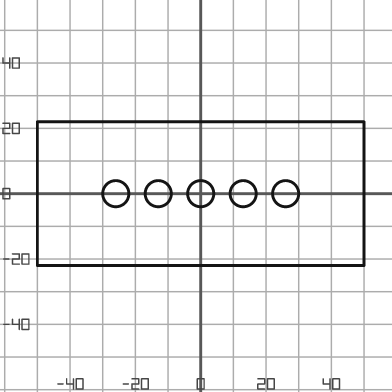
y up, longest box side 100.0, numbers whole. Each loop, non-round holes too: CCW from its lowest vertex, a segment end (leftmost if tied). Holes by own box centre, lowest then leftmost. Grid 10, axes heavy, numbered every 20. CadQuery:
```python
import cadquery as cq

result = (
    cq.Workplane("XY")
    .moveTo(-50.0, -22.0)
    .lineTo(50.0, -22.0)
    .lineTo(50.0, 22.0)
    .lineTo(-50.0, 22.0)
    .close()
    .moveTo(-26.0, 0.0)
    .circle(4.0)
    .moveTo(-13.0, 0.0)
    .circle(4.0)
    .moveTo(0.0, 0.0)
    .circle(4.0)
    .moveTo(13.0, 0.0)
    .circle(4.0)
    .moveTo(26.0, 0.0)
    .circle(4.0)
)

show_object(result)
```